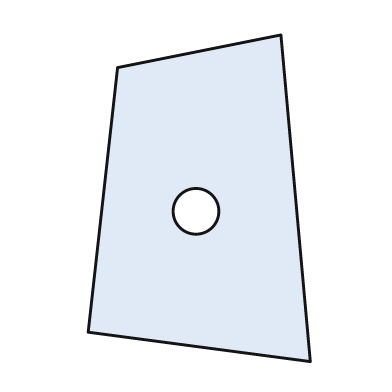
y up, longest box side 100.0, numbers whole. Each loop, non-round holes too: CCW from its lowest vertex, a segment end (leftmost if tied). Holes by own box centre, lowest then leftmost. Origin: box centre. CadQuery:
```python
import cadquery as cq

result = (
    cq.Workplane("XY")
    .moveTo(34.0, -50.0)
    .lineTo(25.0, 50.0)
    .lineTo(-25.0, 40.0)
    .lineTo(-34.0, -41.0)
    .close()
    .moveTo(-1.0, -4.0)
    .circle(7.0)
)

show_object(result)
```